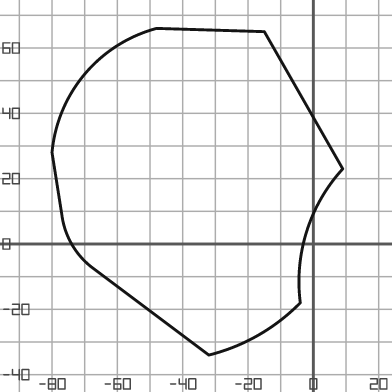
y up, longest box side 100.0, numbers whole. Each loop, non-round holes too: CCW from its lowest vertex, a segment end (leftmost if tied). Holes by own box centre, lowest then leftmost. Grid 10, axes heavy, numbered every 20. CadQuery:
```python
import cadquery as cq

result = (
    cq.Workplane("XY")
    .moveTo(-32.0, -34.0)
    .threePointArc((-17.0, -28.0), (-4.0, -18.0))
    .threePointArc((-2.0, 4.0), (9.0, 23.0))
    .lineTo(-15.0, 65.0)
    .lineTo(-48.0, 66.0)
    .threePointArc((-70.0, 52.0), (-80.0, 28.0))
    .lineTo(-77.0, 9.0)
    .threePointArc((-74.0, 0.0), (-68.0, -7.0))
    .close()
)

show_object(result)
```